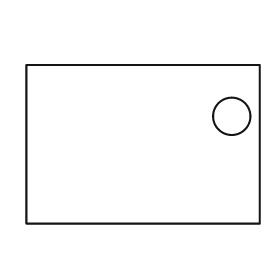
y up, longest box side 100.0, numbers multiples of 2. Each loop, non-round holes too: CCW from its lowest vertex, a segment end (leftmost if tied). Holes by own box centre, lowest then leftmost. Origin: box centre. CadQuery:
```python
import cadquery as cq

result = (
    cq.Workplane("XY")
    .moveTo(-50.0, -34.0)
    .lineTo(50.0, -34.0)
    .lineTo(50.0, 34.0)
    .lineTo(-50.0, 34.0)
    .close()
    .moveTo(38.0, 12.0)
    .circle(8.0)
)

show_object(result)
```